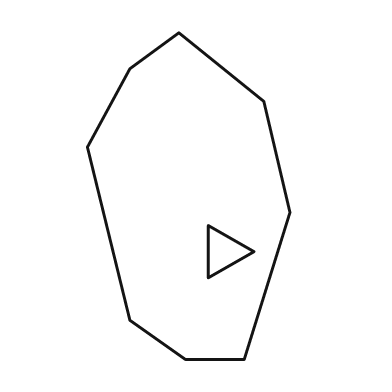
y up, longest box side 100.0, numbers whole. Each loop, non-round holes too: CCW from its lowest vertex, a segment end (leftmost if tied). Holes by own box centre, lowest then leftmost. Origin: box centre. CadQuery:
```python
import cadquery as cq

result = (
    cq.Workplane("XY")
    .moveTo(-1.0, -50.0)
    .lineTo(17.0, -50.0)
    .lineTo(31.0, -5.0)
    .lineTo(23.0, 29.0)
    .lineTo(-3.0, 50.0)
    .lineTo(-18.0, 39.0)
    .lineTo(-31.0, 15.0)
    .lineTo(-18.0, -38.0)
    .close()
    .moveTo(6.0, -25.0)
    .lineTo(20.0, -17.0)
    .lineTo(6.0, -9.0)
    .close()
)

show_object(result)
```